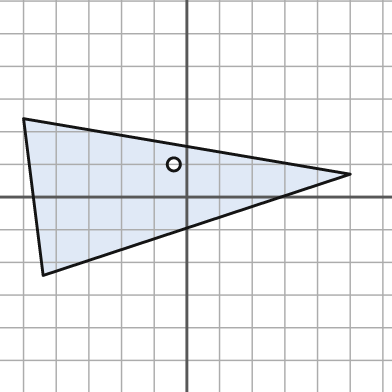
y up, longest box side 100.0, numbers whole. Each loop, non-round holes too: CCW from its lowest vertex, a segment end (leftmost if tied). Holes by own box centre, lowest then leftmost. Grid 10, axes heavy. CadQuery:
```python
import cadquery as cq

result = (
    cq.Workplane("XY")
    .moveTo(-44.0, -24.0)
    .lineTo(50.0, 7.0)
    .lineTo(-50.0, 24.0)
    .close()
    .moveTo(-4.0, 10.0)
    .circle(2.0)
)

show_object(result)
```